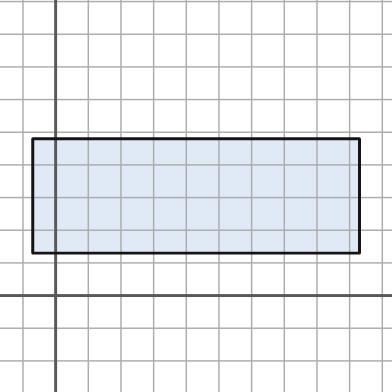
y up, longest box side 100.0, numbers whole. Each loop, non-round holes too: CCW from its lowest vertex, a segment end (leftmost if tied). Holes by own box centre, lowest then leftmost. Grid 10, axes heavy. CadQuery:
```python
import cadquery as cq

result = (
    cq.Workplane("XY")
    .moveTo(-7.0, 13.0)
    .lineTo(93.0, 13.0)
    .lineTo(93.0, 48.0)
    .lineTo(-7.0, 48.0)
    .close()
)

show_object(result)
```